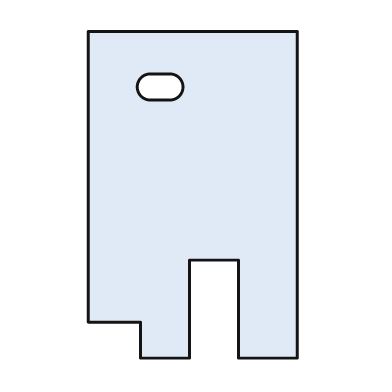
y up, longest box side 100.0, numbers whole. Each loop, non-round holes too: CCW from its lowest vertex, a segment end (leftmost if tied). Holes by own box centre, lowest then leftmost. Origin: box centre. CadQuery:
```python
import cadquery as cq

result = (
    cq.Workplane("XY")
    .moveTo(-16.0, -50.0)
    .lineTo(-1.0, -50.0)
    .lineTo(-1.0, -20.0)
    .lineTo(14.0, -20.0)
    .lineTo(14.0, -50.0)
    .lineTo(32.0, -50.0)
    .lineTo(32.0, 50.0)
    .lineTo(-32.0, 50.0)
    .lineTo(-32.0, -39.0)
    .lineTo(-16.0, -39.0)
    .close()
    .moveTo(-13.0, 29.0)
    .lineTo(-7.0, 29.0)
    .threePointArc((-3.0, 33.0), (-7.0, 37.0))
    .lineTo(-13.0, 37.0)
    .threePointArc((-17.0, 33.0), (-13.0, 29.0))
    .close()
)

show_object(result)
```